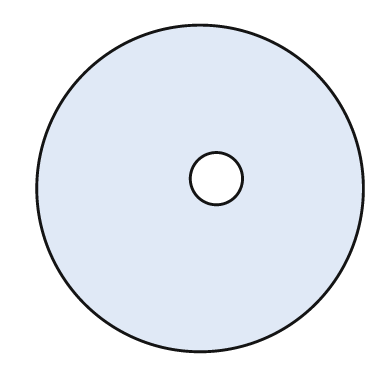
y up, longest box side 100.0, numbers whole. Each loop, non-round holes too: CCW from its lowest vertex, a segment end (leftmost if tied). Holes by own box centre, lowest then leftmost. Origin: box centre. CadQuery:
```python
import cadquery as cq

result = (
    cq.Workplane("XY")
    .moveTo(0.0, 0.0)
    .circle(50.0)
    .moveTo(5.0, 3.0)
    .circle(8.0)
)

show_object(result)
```